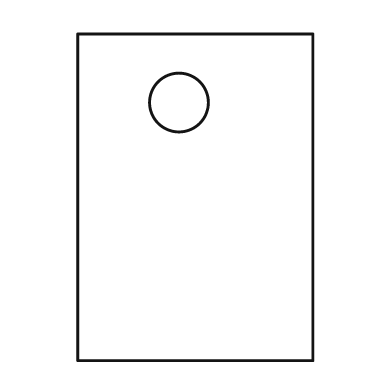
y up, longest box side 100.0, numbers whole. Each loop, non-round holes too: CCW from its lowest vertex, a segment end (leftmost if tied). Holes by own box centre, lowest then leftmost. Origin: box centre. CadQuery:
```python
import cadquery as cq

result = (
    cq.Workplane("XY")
    .moveTo(-36.0, -50.0)
    .lineTo(36.0, -50.0)
    .lineTo(36.0, 50.0)
    .lineTo(-36.0, 50.0)
    .close()
    .moveTo(-5.0, 29.0)
    .circle(9.0)
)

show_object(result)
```